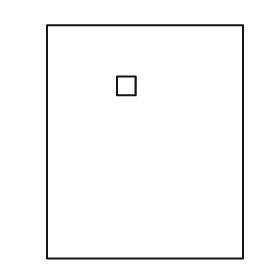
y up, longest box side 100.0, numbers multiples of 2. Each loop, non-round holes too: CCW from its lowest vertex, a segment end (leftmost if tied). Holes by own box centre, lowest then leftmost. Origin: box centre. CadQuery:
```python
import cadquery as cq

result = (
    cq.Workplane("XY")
    .moveTo(-42.0, -50.0)
    .lineTo(42.0, -50.0)
    .lineTo(42.0, 50.0)
    .lineTo(-42.0, 50.0)
    .close()
    .moveTo(-12.0, 20.0)
    .lineTo(-4.0, 20.0)
    .lineTo(-4.0, 28.0)
    .lineTo(-12.0, 28.0)
    .close()
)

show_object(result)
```